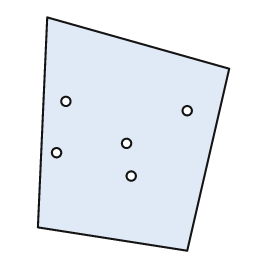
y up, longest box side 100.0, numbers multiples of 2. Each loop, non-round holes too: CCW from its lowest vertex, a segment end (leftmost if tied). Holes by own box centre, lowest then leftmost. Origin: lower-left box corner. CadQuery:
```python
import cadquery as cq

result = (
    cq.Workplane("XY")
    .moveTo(64.0, 0.0)
    .lineTo(82.0, 78.0)
    .lineTo(4.0, 100.0)
    .lineTo(0.0, 10.0)
    .close()
    .moveTo(40.0, 32.0)
    .circle(2.0)
    .moveTo(8.0, 42.0)
    .circle(2.0)
    .moveTo(38.0, 46.0)
    .circle(2.0)
    .moveTo(64.0, 60.0)
    .circle(2.0)
    .moveTo(12.0, 64.0)
    .circle(2.0)
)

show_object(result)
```